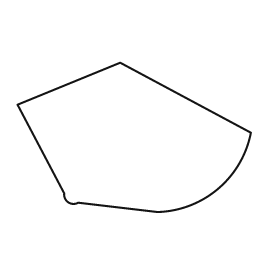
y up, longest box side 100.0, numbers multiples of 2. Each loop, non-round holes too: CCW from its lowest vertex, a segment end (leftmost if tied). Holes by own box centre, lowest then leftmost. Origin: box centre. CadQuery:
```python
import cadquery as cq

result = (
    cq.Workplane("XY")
    .moveTo(10.0, -32.0)
    .threePointArc((36.0, -22.0), (50.0, 2.0))
    .lineTo(-6.0, 32.0)
    .lineTo(-50.0, 14.0)
    .lineTo(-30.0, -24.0)
    .threePointArc((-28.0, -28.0), (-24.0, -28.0))
    .close()
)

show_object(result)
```